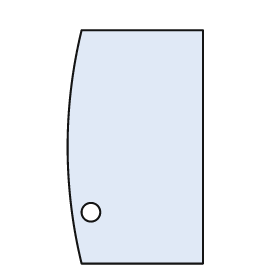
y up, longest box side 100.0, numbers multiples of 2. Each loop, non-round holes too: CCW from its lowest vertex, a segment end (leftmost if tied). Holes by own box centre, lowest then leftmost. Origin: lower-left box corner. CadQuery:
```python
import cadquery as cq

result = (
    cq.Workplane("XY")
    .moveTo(6.0, 0.0)
    .lineTo(58.0, 0.0)
    .lineTo(58.0, 100.0)
    .lineTo(6.0, 100.0)
    .threePointArc((0.0, 50.0), (6.0, 0.0))
    .close()
    .moveTo(10.0, 22.0)
    .circle(4.0)
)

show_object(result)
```